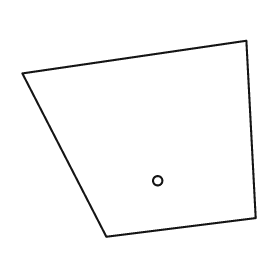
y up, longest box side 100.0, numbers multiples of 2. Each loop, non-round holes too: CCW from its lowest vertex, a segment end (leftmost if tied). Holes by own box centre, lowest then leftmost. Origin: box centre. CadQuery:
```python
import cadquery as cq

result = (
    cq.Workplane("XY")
    .moveTo(-14.0, -42.0)
    .lineTo(50.0, -34.0)
    .lineTo(46.0, 42.0)
    .lineTo(-50.0, 28.0)
    .close()
    .moveTo(8.0, -18.0)
    .circle(2.0)
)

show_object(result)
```